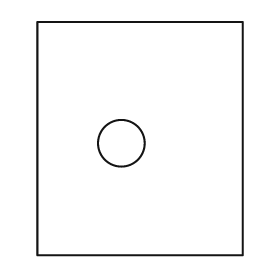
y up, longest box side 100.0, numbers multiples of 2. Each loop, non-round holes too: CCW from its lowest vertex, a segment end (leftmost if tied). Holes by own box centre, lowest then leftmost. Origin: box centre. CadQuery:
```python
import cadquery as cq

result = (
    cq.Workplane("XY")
    .moveTo(-44.0, -50.0)
    .lineTo(44.0, -50.0)
    .lineTo(44.0, 50.0)
    .lineTo(-44.0, 50.0)
    .close()
    .moveTo(-8.0, -2.0)
    .circle(10.0)
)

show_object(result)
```